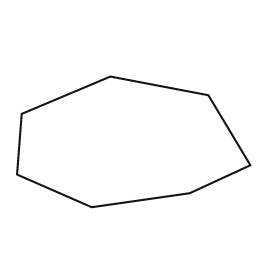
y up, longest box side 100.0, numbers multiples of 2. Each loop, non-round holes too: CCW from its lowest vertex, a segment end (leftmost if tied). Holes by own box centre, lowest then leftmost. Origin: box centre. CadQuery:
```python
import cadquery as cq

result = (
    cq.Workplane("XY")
    .moveTo(-18.0, -28.0)
    .lineTo(24.0, -22.0)
    .lineTo(50.0, -10.0)
    .lineTo(32.0, 20.0)
    .lineTo(-10.0, 28.0)
    .lineTo(-48.0, 12.0)
    .lineTo(-50.0, -14.0)
    .close()
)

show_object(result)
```